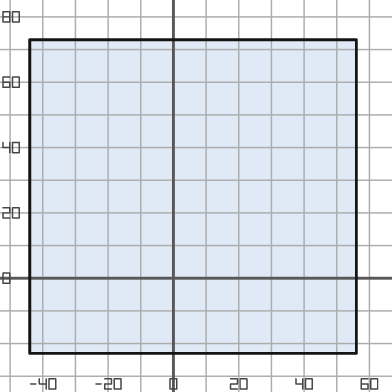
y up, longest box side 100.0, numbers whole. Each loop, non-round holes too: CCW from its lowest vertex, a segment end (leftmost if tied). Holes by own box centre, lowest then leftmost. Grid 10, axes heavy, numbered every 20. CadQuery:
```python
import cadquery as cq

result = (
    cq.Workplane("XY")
    .moveTo(-44.0, -23.0)
    .lineTo(56.0, -23.0)
    .lineTo(56.0, 73.0)
    .lineTo(-44.0, 73.0)
    .close()
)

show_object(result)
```